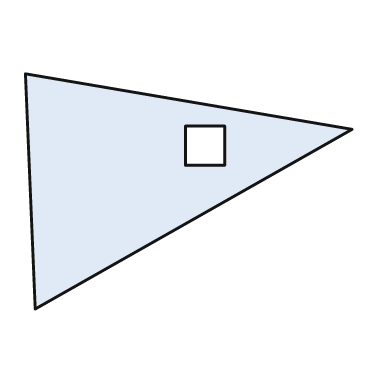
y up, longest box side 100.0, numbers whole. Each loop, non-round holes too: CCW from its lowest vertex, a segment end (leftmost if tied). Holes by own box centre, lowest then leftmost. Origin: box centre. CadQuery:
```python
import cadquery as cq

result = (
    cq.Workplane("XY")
    .moveTo(-47.0, -36.0)
    .lineTo(50.0, 19.0)
    .lineTo(-50.0, 36.0)
    .close()
    .moveTo(-1.0, 8.0)
    .lineTo(11.0, 8.0)
    .lineTo(11.0, 20.0)
    .lineTo(-1.0, 20.0)
    .close()
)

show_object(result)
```